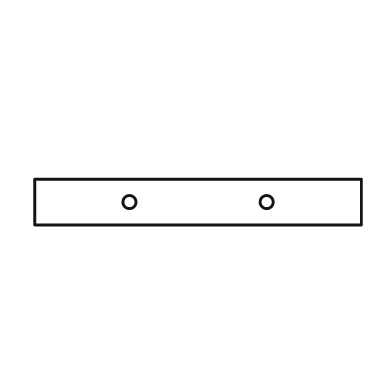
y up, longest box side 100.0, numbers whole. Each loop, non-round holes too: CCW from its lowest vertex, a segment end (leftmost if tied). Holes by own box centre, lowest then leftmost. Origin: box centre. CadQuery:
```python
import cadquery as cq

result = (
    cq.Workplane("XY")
    .moveTo(-50.0, -7.0)
    .lineTo(50.0, -7.0)
    .lineTo(50.0, 7.0)
    .lineTo(-50.0, 7.0)
    .close()
    .moveTo(-21.0, 0.0)
    .circle(2.0)
    .moveTo(21.0, 0.0)
    .circle(2.0)
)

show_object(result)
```